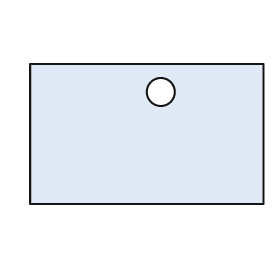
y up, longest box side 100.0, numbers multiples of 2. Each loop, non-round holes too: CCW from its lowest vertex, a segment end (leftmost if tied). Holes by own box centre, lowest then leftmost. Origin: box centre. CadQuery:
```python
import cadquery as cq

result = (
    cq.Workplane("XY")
    .moveTo(-50.0, -30.0)
    .lineTo(50.0, -30.0)
    .lineTo(50.0, 30.0)
    .lineTo(-50.0, 30.0)
    .close()
    .moveTo(6.0, 18.0)
    .circle(6.0)
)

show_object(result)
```